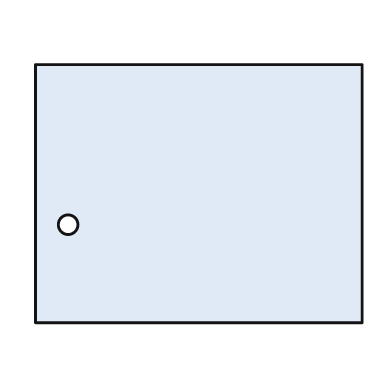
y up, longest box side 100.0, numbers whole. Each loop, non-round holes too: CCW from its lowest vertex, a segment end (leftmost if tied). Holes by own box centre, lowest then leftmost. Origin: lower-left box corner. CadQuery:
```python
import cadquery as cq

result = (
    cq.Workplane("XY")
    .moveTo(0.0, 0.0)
    .lineTo(100.0, 0.0)
    .lineTo(100.0, 79.0)
    .lineTo(0.0, 79.0)
    .close()
    .moveTo(10.0, 30.0)
    .circle(3.0)
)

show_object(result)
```